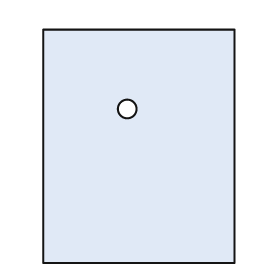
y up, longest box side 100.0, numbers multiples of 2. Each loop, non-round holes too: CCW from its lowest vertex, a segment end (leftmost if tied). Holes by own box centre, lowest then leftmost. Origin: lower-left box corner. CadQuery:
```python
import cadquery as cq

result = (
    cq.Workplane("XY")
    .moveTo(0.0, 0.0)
    .lineTo(82.0, 0.0)
    .lineTo(82.0, 100.0)
    .lineTo(0.0, 100.0)
    .close()
    .moveTo(36.0, 66.0)
    .circle(4.0)
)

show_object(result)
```